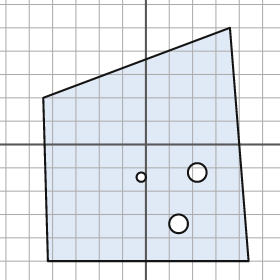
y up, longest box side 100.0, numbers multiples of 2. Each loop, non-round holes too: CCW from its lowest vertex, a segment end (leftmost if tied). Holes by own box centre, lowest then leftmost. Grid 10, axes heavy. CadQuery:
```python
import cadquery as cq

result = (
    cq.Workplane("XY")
    .moveTo(-42.0, -50.0)
    .lineTo(44.0, -50.0)
    .lineTo(36.0, 50.0)
    .lineTo(-44.0, 20.0)
    .close()
    .moveTo(14.0, -34.0)
    .circle(4.0)
    .moveTo(-2.0, -14.0)
    .circle(2.0)
    .moveTo(22.0, -12.0)
    .circle(4.0)
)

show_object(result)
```